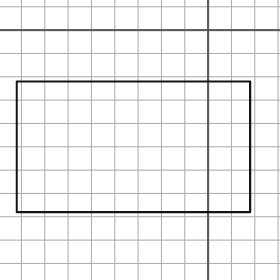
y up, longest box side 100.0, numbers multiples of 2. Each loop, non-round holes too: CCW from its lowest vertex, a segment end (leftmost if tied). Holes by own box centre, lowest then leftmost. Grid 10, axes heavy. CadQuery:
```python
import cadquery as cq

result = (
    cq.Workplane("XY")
    .moveTo(-82.0, -78.0)
    .lineTo(18.0, -78.0)
    .lineTo(18.0, -22.0)
    .lineTo(-82.0, -22.0)
    .close()
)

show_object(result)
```